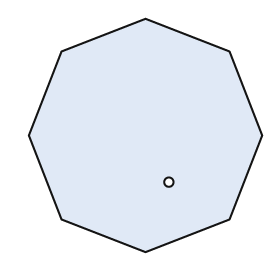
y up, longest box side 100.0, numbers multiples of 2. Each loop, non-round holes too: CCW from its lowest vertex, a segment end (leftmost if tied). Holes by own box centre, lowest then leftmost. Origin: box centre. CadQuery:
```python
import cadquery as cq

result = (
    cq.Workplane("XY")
    .moveTo(0.0, -50.0)
    .lineTo(36.0, -36.0)
    .lineTo(50.0, 0.0)
    .lineTo(36.0, 36.0)
    .lineTo(0.0, 50.0)
    .lineTo(-36.0, 36.0)
    .lineTo(-50.0, 0.0)
    .lineTo(-36.0, -36.0)
    .close()
    .moveTo(10.0, -20.0)
    .circle(2.0)
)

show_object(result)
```